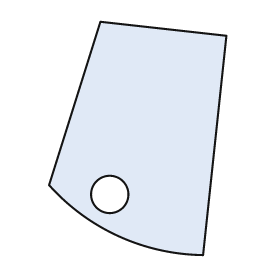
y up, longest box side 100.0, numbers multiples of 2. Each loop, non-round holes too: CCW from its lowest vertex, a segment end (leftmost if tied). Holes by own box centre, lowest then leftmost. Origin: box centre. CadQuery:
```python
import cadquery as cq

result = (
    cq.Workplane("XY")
    .moveTo(28.0, -50.0)
    .lineTo(38.0, 44.0)
    .lineTo(-16.0, 50.0)
    .lineTo(-38.0, -20.0)
    .threePointArc((-8.0, -42.0), (28.0, -50.0))
    .close()
    .moveTo(-12.0, -24.0)
    .circle(8.0)
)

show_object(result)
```